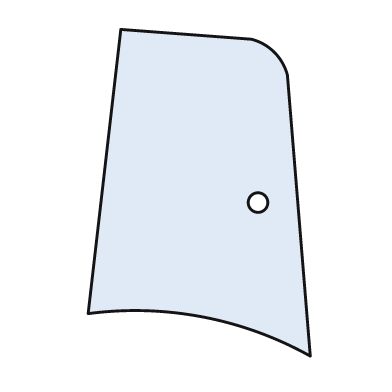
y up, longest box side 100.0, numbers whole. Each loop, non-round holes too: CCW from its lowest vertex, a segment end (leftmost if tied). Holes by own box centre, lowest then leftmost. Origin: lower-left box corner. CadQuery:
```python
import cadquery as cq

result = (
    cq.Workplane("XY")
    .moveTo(68.0, 0.0)
    .lineTo(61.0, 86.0)
    .threePointArc((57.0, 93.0), (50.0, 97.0))
    .lineTo(10.0, 100.0)
    .lineTo(0.0, 13.0)
    .threePointArc((35.0, 12.0), (68.0, 0.0))
    .close()
    .moveTo(52.0, 47.0)
    .circle(3.0)
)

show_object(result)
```